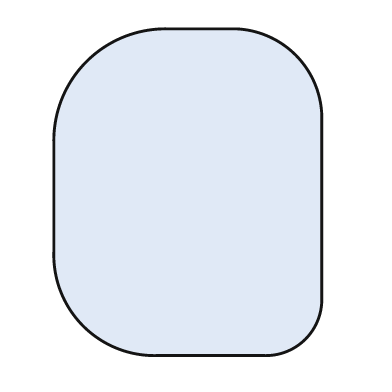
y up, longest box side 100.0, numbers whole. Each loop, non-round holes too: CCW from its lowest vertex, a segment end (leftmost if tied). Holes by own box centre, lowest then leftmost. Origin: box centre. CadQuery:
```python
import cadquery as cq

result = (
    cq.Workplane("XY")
    .moveTo(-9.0, -50.0)
    .lineTo(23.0, -50.0)
    .threePointArc((36.0, -45.0), (41.0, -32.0))
    .lineTo(41.0, 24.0)
    .threePointArc((33.0, 42.0), (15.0, 50.0))
    .lineTo(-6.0, 50.0)
    .threePointArc((-31.0, 40.0), (-41.0, 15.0))
    .lineTo(-41.0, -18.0)
    .threePointArc((-32.0, -41.0), (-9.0, -50.0))
    .close()
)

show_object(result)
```